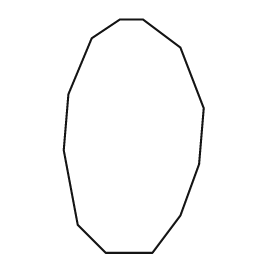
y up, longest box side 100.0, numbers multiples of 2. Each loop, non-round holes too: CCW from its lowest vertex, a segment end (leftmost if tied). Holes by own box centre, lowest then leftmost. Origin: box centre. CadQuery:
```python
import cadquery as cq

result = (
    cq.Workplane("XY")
    .moveTo(-12.0, -50.0)
    .lineTo(8.0, -50.0)
    .lineTo(20.0, -34.0)
    .lineTo(28.0, -12.0)
    .lineTo(30.0, 12.0)
    .lineTo(20.0, 38.0)
    .lineTo(4.0, 50.0)
    .lineTo(-6.0, 50.0)
    .lineTo(-18.0, 42.0)
    .lineTo(-28.0, 18.0)
    .lineTo(-30.0, -6.0)
    .lineTo(-24.0, -38.0)
    .close()
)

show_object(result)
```